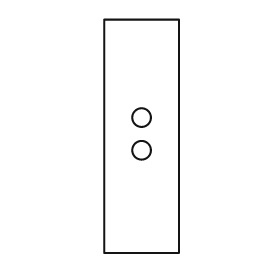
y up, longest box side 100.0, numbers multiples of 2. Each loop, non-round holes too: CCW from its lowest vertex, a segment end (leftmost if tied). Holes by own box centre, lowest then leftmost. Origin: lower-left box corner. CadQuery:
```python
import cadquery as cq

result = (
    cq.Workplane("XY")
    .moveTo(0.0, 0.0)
    .lineTo(32.0, 0.0)
    .lineTo(32.0, 100.0)
    .lineTo(0.0, 100.0)
    .close()
    .moveTo(16.0, 44.0)
    .circle(4.0)
    .moveTo(16.0, 58.0)
    .circle(4.0)
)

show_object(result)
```